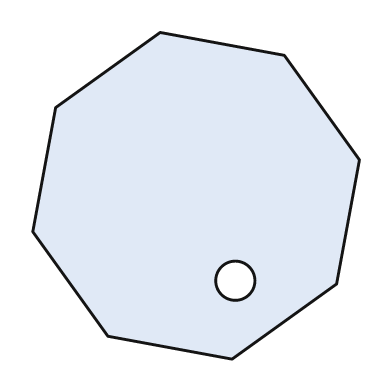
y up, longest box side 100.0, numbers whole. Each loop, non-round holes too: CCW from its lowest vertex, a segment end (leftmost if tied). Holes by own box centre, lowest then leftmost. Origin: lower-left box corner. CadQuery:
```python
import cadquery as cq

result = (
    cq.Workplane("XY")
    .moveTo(61.0, 0.0)
    .lineTo(93.0, 23.0)
    .lineTo(100.0, 61.0)
    .lineTo(77.0, 93.0)
    .lineTo(39.0, 100.0)
    .lineTo(7.0, 77.0)
    .lineTo(0.0, 39.0)
    .lineTo(23.0, 7.0)
    .close()
    .moveTo(62.0, 24.0)
    .circle(6.0)
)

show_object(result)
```